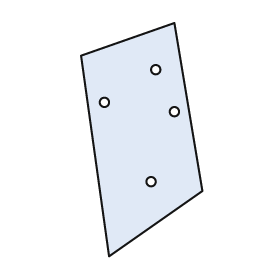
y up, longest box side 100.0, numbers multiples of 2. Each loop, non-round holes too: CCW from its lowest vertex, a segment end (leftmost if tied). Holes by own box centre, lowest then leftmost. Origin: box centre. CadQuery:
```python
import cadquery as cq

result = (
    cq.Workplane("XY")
    .moveTo(-14.0, -50.0)
    .lineTo(26.0, -22.0)
    .lineTo(14.0, 50.0)
    .lineTo(-26.0, 36.0)
    .close()
    .moveTo(4.0, -18.0)
    .circle(2.0)
    .moveTo(14.0, 12.0)
    .circle(2.0)
    .moveTo(-16.0, 16.0)
    .circle(2.0)
    .moveTo(6.0, 30.0)
    .circle(2.0)
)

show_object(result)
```